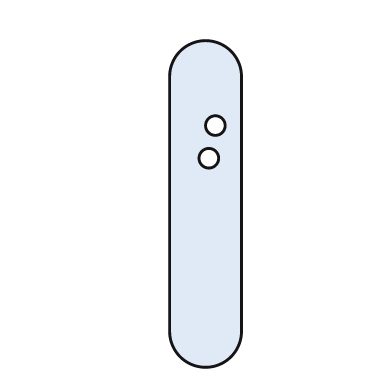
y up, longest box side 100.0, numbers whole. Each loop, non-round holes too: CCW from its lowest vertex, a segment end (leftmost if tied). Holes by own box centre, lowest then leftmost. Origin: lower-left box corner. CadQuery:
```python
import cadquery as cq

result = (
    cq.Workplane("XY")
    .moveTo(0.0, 11.0)
    .threePointArc((11.0, 0.0), (22.0, 11.0))
    .lineTo(22.0, 89.0)
    .threePointArc((11.0, 100.0), (0.0, 89.0))
    .close()
    .moveTo(12.0, 64.0)
    .circle(3.0)
    .moveTo(14.0, 74.0)
    .circle(3.0)
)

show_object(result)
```